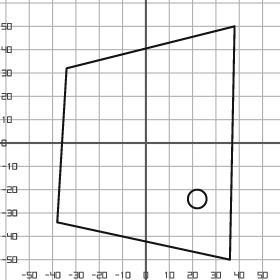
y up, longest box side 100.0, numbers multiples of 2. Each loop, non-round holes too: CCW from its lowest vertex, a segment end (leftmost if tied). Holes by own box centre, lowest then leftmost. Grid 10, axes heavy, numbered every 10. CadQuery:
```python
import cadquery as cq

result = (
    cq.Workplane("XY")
    .moveTo(36.0, -50.0)
    .lineTo(38.0, 50.0)
    .lineTo(-34.0, 32.0)
    .lineTo(-38.0, -34.0)
    .close()
    .moveTo(22.0, -24.0)
    .circle(4.0)
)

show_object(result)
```